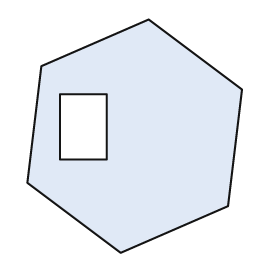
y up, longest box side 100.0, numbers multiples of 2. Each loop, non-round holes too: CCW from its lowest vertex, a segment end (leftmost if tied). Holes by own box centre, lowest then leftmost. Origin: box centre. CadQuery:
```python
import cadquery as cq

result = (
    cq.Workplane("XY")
    .moveTo(-6.0, -50.0)
    .lineTo(40.0, -30.0)
    .lineTo(46.0, 20.0)
    .lineTo(6.0, 50.0)
    .lineTo(-40.0, 30.0)
    .lineTo(-46.0, -20.0)
    .close()
    .moveTo(-32.0, -10.0)
    .lineTo(-12.0, -10.0)
    .lineTo(-12.0, 18.0)
    .lineTo(-32.0, 18.0)
    .close()
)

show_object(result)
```